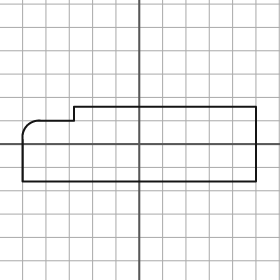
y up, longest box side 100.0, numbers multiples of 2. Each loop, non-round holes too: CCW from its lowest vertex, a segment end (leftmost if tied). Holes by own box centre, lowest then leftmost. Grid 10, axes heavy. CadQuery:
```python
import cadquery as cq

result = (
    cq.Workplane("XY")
    .moveTo(-50.0, -16.0)
    .lineTo(50.0, -16.0)
    .lineTo(50.0, 16.0)
    .lineTo(-28.0, 16.0)
    .lineTo(-28.0, 10.0)
    .lineTo(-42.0, 10.0)
    .threePointArc((-48.0, 8.0), (-50.0, 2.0))
    .close()
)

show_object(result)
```